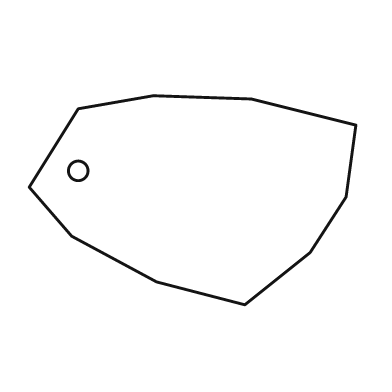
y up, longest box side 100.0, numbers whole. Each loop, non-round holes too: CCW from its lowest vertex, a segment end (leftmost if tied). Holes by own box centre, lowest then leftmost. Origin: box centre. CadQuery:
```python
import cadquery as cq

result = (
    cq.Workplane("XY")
    .moveTo(16.0, -32.0)
    .lineTo(36.0, -16.0)
    .lineTo(47.0, 1.0)
    .lineTo(50.0, 23.0)
    .lineTo(18.0, 31.0)
    .lineTo(-12.0, 32.0)
    .lineTo(-35.0, 28.0)
    .lineTo(-50.0, 4.0)
    .lineTo(-37.0, -11.0)
    .lineTo(-11.0, -25.0)
    .close()
    .moveTo(-35.0, 9.0)
    .circle(3.0)
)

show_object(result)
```